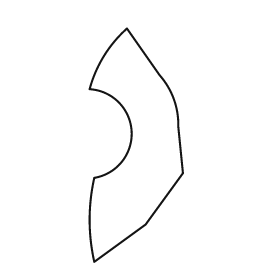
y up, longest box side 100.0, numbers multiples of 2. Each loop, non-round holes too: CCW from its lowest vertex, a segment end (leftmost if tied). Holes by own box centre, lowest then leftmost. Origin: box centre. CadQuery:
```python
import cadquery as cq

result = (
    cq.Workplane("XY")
    .moveTo(-18.0, -50.0)
    .lineTo(4.0, -34.0)
    .lineTo(20.0, -12.0)
    .lineTo(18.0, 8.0)
    .threePointArc((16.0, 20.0), (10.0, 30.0))
    .lineTo(-4.0, 50.0)
    .threePointArc((-14.0, 38.0), (-20.0, 24.0))
    .threePointArc((-2.0, 6.0), (-18.0, -14.0))
    .threePointArc((-20.0, -32.0), (-18.0, -50.0))
    .close()
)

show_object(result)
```